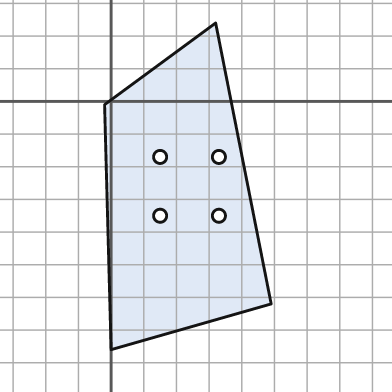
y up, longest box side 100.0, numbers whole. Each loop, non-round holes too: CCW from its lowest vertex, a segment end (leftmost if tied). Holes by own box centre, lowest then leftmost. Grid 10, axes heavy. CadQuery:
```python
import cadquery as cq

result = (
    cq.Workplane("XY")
    .moveTo(0.0, -76.0)
    .lineTo(49.0, -62.0)
    .lineTo(32.0, 24.0)
    .lineTo(-2.0, -1.0)
    .close()
    .moveTo(15.0, -35.0)
    .circle(2.0)
    .moveTo(33.0, -35.0)
    .circle(2.0)
    .moveTo(15.0, -17.0)
    .circle(2.0)
    .moveTo(33.0, -17.0)
    .circle(2.0)
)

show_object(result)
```